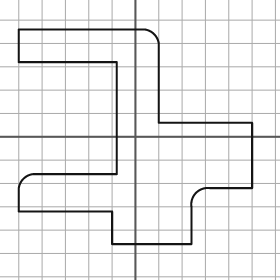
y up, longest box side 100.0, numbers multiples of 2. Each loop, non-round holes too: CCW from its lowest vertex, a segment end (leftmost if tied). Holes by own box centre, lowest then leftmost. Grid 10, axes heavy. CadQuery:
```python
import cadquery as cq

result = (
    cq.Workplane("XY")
    .moveTo(-10.0, -46.0)
    .lineTo(24.0, -46.0)
    .lineTo(24.0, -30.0)
    .threePointArc((26.0, -24.0), (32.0, -22.0))
    .lineTo(50.0, -22.0)
    .lineTo(50.0, 6.0)
    .lineTo(10.0, 6.0)
    .lineTo(10.0, 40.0)
    .threePointArc((8.0, 44.0), (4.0, 46.0))
    .lineTo(-50.0, 46.0)
    .lineTo(-50.0, 32.0)
    .lineTo(-8.0, 32.0)
    .lineTo(-8.0, -16.0)
    .lineTo(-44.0, -16.0)
    .threePointArc((-48.0, -18.0), (-50.0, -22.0))
    .lineTo(-50.0, -32.0)
    .lineTo(-10.0, -32.0)
    .close()
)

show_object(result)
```